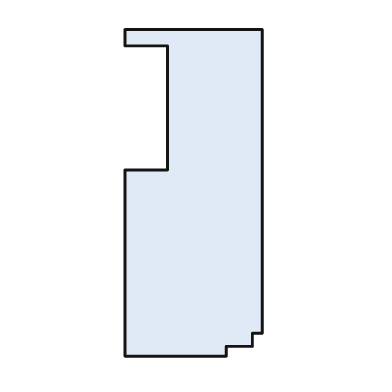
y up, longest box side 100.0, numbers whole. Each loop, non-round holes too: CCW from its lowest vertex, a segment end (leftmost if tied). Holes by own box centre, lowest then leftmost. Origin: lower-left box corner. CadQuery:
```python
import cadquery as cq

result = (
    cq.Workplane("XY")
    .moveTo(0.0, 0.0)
    .lineTo(31.0, 0.0)
    .lineTo(31.0, 3.0)
    .lineTo(39.0, 3.0)
    .lineTo(39.0, 7.0)
    .lineTo(42.0, 7.0)
    .lineTo(42.0, 100.0)
    .lineTo(0.0, 100.0)
    .lineTo(0.0, 95.0)
    .lineTo(13.0, 95.0)
    .lineTo(13.0, 57.0)
    .lineTo(0.0, 57.0)
    .close()
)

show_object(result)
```